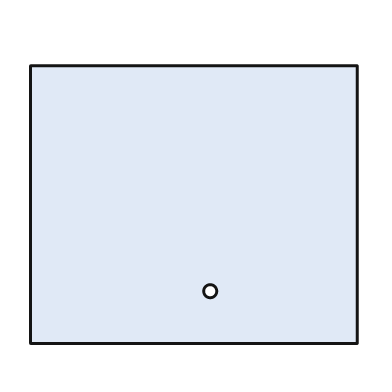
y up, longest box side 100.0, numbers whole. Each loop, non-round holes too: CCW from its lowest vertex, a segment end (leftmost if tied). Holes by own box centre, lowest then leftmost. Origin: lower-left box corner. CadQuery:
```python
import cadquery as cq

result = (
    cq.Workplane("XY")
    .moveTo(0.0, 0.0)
    .lineTo(100.0, 0.0)
    .lineTo(100.0, 85.0)
    .lineTo(0.0, 85.0)
    .close()
    .moveTo(55.0, 16.0)
    .circle(2.0)
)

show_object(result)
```